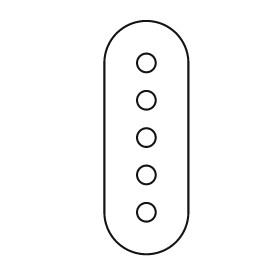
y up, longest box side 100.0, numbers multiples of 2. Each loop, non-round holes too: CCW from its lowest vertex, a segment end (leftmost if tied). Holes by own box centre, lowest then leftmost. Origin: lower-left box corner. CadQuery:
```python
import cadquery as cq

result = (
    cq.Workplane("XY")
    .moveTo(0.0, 18.0)
    .threePointArc((18.0, 0.0), (36.0, 18.0))
    .lineTo(36.0, 82.0)
    .threePointArc((18.0, 100.0), (0.0, 82.0))
    .close()
    .moveTo(18.0, 18.0)
    .circle(4.0)
    .moveTo(18.0, 34.0)
    .circle(4.0)
    .moveTo(18.0, 50.0)
    .circle(4.0)
    .moveTo(18.0, 66.0)
    .circle(4.0)
    .moveTo(18.0, 82.0)
    .circle(4.0)
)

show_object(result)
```